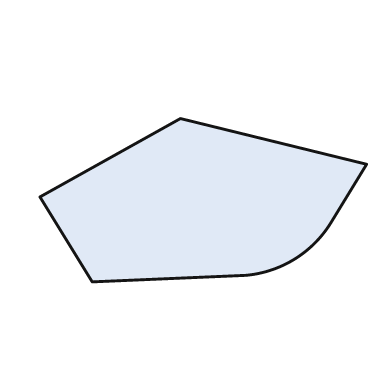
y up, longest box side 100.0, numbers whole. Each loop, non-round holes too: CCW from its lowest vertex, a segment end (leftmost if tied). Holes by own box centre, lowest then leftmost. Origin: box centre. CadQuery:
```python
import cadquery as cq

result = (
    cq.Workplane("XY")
    .moveTo(-34.0, -25.0)
    .lineTo(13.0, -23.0)
    .threePointArc((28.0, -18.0), (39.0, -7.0))
    .lineTo(50.0, 11.0)
    .lineTo(-7.0, 25.0)
    .lineTo(-50.0, 1.0)
    .close()
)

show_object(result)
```